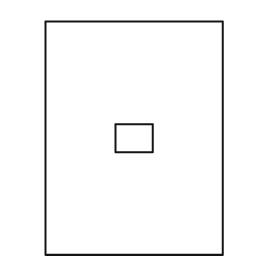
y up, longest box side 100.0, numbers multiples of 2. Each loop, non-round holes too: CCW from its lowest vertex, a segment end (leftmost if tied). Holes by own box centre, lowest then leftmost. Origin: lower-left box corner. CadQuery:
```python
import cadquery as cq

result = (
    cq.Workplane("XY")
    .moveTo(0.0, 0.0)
    .lineTo(76.0, 0.0)
    .lineTo(76.0, 100.0)
    .lineTo(0.0, 100.0)
    .close()
    .moveTo(30.0, 44.0)
    .lineTo(46.0, 44.0)
    .lineTo(46.0, 56.0)
    .lineTo(30.0, 56.0)
    .close()
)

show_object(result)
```